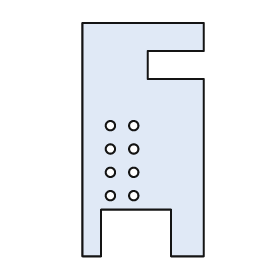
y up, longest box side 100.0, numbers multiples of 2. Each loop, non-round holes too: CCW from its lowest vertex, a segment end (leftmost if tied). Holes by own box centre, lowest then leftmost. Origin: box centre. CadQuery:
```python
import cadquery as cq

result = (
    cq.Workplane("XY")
    .moveTo(-26.0, -50.0)
    .lineTo(-18.0, -50.0)
    .lineTo(-18.0, -30.0)
    .lineTo(12.0, -30.0)
    .lineTo(12.0, -50.0)
    .lineTo(26.0, -50.0)
    .lineTo(26.0, 26.0)
    .lineTo(2.0, 26.0)
    .lineTo(2.0, 38.0)
    .lineTo(26.0, 38.0)
    .lineTo(26.0, 50.0)
    .lineTo(-26.0, 50.0)
    .close()
    .moveTo(-14.0, -24.0)
    .circle(2.0)
    .moveTo(-4.0, -24.0)
    .circle(2.0)
    .moveTo(-14.0, -14.0)
    .circle(2.0)
    .moveTo(-4.0, -14.0)
    .circle(2.0)
    .moveTo(-14.0, -4.0)
    .circle(2.0)
    .moveTo(-4.0, -4.0)
    .circle(2.0)
    .moveTo(-14.0, 6.0)
    .circle(2.0)
    .moveTo(-4.0, 6.0)
    .circle(2.0)
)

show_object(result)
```